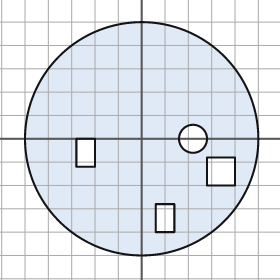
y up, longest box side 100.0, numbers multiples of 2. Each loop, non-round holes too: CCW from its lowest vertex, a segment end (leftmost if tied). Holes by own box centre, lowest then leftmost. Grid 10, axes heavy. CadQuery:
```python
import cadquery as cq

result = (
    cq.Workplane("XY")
    .moveTo(0.0, 0.0)
    .circle(50.0)
    .moveTo(6.0, -40.0)
    .lineTo(14.0, -40.0)
    .lineTo(14.0, -28.0)
    .lineTo(6.0, -28.0)
    .close()
    .moveTo(28.0, -20.0)
    .lineTo(40.0, -20.0)
    .lineTo(40.0, -8.0)
    .lineTo(28.0, -8.0)
    .close()
    .moveTo(-28.0, -12.0)
    .lineTo(-20.0, -12.0)
    .lineTo(-20.0, 0.0)
    .lineTo(-28.0, 0.0)
    .close()
    .moveTo(22.0, 0.0)
    .circle(6.0)
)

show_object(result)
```